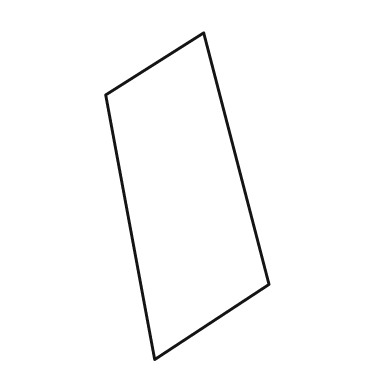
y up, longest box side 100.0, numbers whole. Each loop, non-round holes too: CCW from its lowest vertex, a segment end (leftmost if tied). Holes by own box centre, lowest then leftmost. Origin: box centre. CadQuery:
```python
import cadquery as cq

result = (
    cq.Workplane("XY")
    .moveTo(-10.0, -50.0)
    .lineTo(25.0, -27.0)
    .lineTo(5.0, 50.0)
    .lineTo(-25.0, 31.0)
    .close()
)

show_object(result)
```